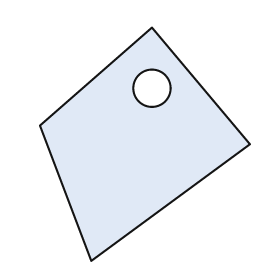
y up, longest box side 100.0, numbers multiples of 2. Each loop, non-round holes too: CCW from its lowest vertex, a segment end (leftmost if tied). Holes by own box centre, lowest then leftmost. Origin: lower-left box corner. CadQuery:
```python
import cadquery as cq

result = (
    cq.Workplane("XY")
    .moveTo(22.0, 0.0)
    .lineTo(90.0, 50.0)
    .lineTo(48.0, 100.0)
    .lineTo(0.0, 58.0)
    .close()
    .moveTo(48.0, 74.0)
    .circle(8.0)
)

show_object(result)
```